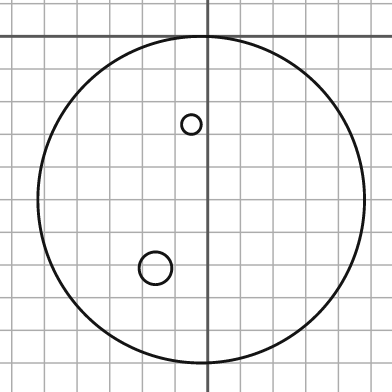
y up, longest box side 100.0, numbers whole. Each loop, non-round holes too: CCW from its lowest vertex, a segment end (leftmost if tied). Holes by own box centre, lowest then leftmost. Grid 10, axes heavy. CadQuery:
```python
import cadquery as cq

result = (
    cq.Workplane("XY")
    .moveTo(-2.0, -50.0)
    .circle(50.0)
    .moveTo(-16.0, -71.0)
    .circle(5.0)
    .moveTo(-5.0, -27.0)
    .circle(3.0)
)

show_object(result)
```